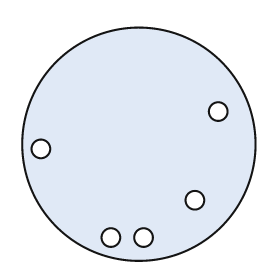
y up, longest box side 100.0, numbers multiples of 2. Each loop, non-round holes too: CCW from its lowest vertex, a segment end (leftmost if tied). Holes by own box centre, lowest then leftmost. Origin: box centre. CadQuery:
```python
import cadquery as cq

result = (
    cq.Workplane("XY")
    .moveTo(0.0, 0.0)
    .circle(50.0)
    .moveTo(-12.0, -40.0)
    .circle(4.0)
    .moveTo(2.0, -40.0)
    .circle(4.0)
    .moveTo(24.0, -24.0)
    .circle(4.0)
    .moveTo(-42.0, -2.0)
    .circle(4.0)
    .moveTo(34.0, 14.0)
    .circle(4.0)
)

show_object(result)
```